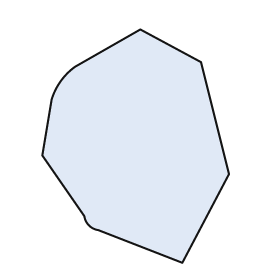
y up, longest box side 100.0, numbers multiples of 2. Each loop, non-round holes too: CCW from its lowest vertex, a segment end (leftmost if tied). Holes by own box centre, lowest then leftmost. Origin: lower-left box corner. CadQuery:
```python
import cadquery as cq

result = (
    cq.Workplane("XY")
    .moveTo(60.0, 0.0)
    .lineTo(80.0, 38.0)
    .lineTo(68.0, 86.0)
    .lineTo(42.0, 100.0)
    .lineTo(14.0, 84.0)
    .threePointArc((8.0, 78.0), (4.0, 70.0))
    .lineTo(0.0, 46.0)
    .lineTo(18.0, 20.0)
    .threePointArc((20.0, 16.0), (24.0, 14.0))
    .close()
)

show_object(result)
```